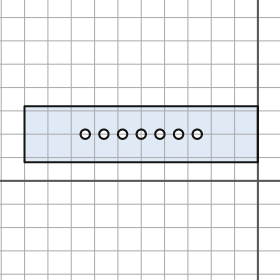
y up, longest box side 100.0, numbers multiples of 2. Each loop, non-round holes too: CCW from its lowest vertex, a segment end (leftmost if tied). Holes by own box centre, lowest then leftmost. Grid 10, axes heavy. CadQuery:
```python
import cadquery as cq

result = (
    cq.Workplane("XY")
    .moveTo(-100.0, 8.0)
    .lineTo(0.0, 8.0)
    .lineTo(0.0, 32.0)
    .lineTo(-100.0, 32.0)
    .close()
    .moveTo(-74.0, 20.0)
    .circle(2.0)
    .moveTo(-66.0, 20.0)
    .circle(2.0)
    .moveTo(-58.0, 20.0)
    .circle(2.0)
    .moveTo(-50.0, 20.0)
    .circle(2.0)
    .moveTo(-42.0, 20.0)
    .circle(2.0)
    .moveTo(-34.0, 20.0)
    .circle(2.0)
    .moveTo(-26.0, 20.0)
    .circle(2.0)
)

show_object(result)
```